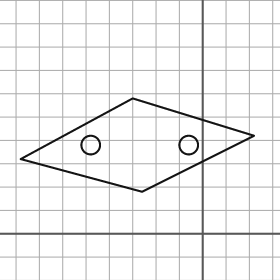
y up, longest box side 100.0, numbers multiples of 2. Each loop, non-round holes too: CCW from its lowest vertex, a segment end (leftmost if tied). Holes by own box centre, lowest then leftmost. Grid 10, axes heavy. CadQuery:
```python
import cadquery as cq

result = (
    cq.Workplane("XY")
    .moveTo(-26.0, 18.0)
    .lineTo(22.0, 42.0)
    .lineTo(-30.0, 58.0)
    .lineTo(-78.0, 32.0)
    .close()
    .moveTo(-48.0, 38.0)
    .circle(4.0)
    .moveTo(-6.0, 38.0)
    .circle(4.0)
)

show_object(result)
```